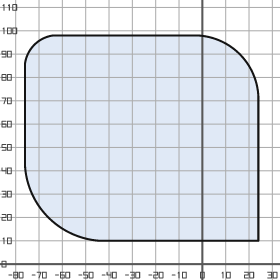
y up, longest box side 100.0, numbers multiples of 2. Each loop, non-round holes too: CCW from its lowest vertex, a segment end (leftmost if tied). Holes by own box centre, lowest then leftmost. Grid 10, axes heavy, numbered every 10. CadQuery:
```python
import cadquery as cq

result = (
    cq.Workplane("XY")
    .moveTo(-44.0, 10.0)
    .lineTo(24.0, 10.0)
    .lineTo(24.0, 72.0)
    .threePointArc((16.0, 90.0), (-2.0, 98.0))
    .lineTo(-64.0, 98.0)
    .threePointArc((-72.0, 94.0), (-76.0, 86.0))
    .lineTo(-76.0, 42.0)
    .threePointArc((-66.0, 20.0), (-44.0, 10.0))
    .close()
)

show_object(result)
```